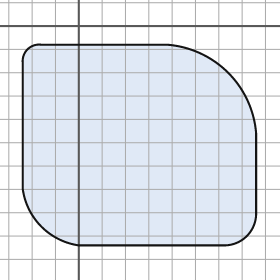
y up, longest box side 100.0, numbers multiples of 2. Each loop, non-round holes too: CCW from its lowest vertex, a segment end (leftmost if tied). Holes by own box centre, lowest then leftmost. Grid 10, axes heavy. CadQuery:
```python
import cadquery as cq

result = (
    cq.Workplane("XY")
    .moveTo(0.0, -94.0)
    .lineTo(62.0, -94.0)
    .threePointArc((72.0, -90.0), (76.0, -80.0))
    .lineTo(76.0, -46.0)
    .threePointArc((64.0, -20.0), (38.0, -8.0))
    .lineTo(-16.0, -8.0)
    .threePointArc((-22.0, -10.0), (-24.0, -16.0))
    .lineTo(-24.0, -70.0)
    .threePointArc((-16.0, -86.0), (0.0, -94.0))
    .close()
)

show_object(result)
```